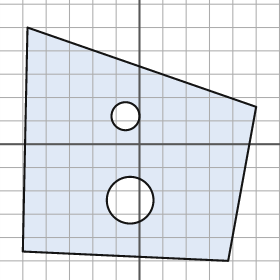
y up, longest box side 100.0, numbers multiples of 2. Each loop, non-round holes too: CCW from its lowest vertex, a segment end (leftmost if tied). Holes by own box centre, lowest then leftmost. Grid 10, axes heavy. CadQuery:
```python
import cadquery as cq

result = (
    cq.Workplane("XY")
    .moveTo(38.0, -50.0)
    .lineTo(50.0, 16.0)
    .lineTo(-48.0, 50.0)
    .lineTo(-50.0, -46.0)
    .close()
    .moveTo(-4.0, -24.0)
    .circle(10.0)
    .moveTo(-6.0, 12.0)
    .circle(6.0)
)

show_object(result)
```